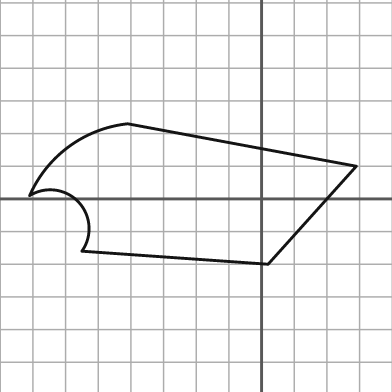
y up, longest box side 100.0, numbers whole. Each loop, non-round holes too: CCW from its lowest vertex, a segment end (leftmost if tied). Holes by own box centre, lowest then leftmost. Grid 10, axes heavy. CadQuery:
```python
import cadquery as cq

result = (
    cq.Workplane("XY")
    .moveTo(2.0, -20.0)
    .lineTo(29.0, 10.0)
    .lineTo(-41.0, 23.0)
    .threePointArc((-59.0, 16.0), (-71.0, 1.0))
    .threePointArc((-56.0, -1.0), (-55.0, -16.0))
    .close()
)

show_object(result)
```